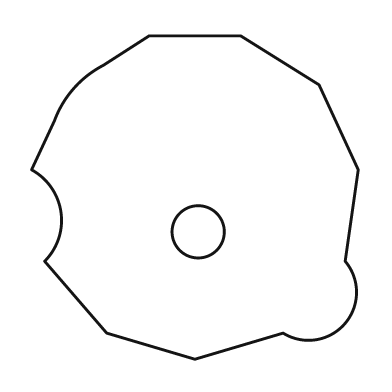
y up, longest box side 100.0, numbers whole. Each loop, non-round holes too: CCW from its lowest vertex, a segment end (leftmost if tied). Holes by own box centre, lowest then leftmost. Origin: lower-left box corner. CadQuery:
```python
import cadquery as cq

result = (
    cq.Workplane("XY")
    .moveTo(50.0, 0.0)
    .lineTo(77.0, 8.0)
    .threePointArc((96.0, 11.0), (96.0, 30.0))
    .lineTo(100.0, 58.0)
    .lineTo(88.0, 84.0)
    .lineTo(64.0, 99.0)
    .lineTo(36.0, 99.0)
    .lineTo(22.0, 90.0)
    .threePointArc((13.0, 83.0), (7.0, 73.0))
    .lineTo(0.0, 58.0)
    .threePointArc((9.0, 45.0), (4.0, 30.0))
    .lineTo(23.0, 8.0)
    .close()
    .moveTo(51.0, 39.0)
    .circle(8.0)
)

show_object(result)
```